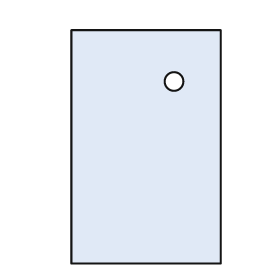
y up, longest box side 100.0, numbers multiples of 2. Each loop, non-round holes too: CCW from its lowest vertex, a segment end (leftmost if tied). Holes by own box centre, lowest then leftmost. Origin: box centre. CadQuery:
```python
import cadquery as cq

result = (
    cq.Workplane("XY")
    .moveTo(-32.0, -50.0)
    .lineTo(32.0, -50.0)
    .lineTo(32.0, 50.0)
    .lineTo(-32.0, 50.0)
    .close()
    .moveTo(12.0, 28.0)
    .circle(4.0)
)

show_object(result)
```